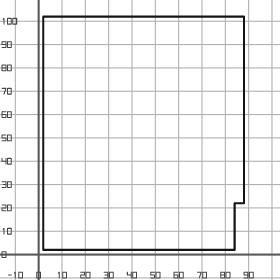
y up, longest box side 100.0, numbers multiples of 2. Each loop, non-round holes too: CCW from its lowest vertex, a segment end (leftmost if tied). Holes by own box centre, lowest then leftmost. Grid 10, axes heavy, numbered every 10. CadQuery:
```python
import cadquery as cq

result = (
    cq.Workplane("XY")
    .moveTo(2.0, 2.0)
    .lineTo(84.0, 2.0)
    .lineTo(84.0, 22.0)
    .lineTo(88.0, 22.0)
    .lineTo(88.0, 102.0)
    .lineTo(2.0, 102.0)
    .close()
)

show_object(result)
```